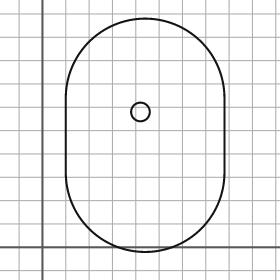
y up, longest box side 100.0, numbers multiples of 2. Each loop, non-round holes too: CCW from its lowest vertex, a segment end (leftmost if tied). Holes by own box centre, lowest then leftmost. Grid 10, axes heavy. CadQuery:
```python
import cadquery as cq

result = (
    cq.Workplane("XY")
    .moveTo(10.0, 32.0)
    .threePointArc((44.0, -2.0), (78.0, 32.0))
    .lineTo(78.0, 64.0)
    .threePointArc((44.0, 98.0), (10.0, 64.0))
    .close()
    .moveTo(42.0, 58.0)
    .circle(4.0)
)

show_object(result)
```